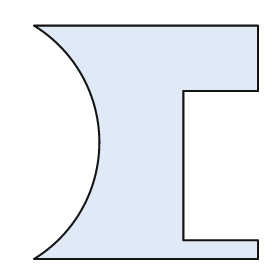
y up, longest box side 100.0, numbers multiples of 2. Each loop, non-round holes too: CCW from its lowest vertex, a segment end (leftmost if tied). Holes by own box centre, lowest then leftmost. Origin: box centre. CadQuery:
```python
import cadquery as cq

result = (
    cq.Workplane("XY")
    .moveTo(-48.0, -50.0)
    .lineTo(48.0, -50.0)
    .lineTo(48.0, -42.0)
    .lineTo(16.0, -42.0)
    .lineTo(16.0, 22.0)
    .lineTo(48.0, 22.0)
    .lineTo(48.0, 50.0)
    .lineTo(-48.0, 50.0)
    .threePointArc((-20.0, 0.0), (-48.0, -50.0))
    .close()
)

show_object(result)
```